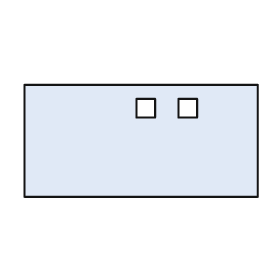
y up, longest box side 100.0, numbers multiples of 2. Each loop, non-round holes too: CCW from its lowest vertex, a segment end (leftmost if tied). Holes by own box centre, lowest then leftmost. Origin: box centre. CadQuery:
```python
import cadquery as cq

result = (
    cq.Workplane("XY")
    .moveTo(-50.0, -24.0)
    .lineTo(50.0, -24.0)
    .lineTo(50.0, 24.0)
    .lineTo(-50.0, 24.0)
    .close()
    .moveTo(-2.0, 10.0)
    .lineTo(6.0, 10.0)
    .lineTo(6.0, 18.0)
    .lineTo(-2.0, 18.0)
    .close()
    .moveTo(16.0, 10.0)
    .lineTo(24.0, 10.0)
    .lineTo(24.0, 18.0)
    .lineTo(16.0, 18.0)
    .close()
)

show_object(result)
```